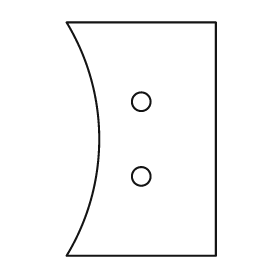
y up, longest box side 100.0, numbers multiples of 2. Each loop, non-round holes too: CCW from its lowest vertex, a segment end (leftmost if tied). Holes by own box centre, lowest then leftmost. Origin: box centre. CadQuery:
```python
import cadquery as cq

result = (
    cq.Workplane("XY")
    .moveTo(-32.0, -50.0)
    .lineTo(32.0, -50.0)
    .lineTo(32.0, 50.0)
    .lineTo(-32.0, 50.0)
    .threePointArc((-18.0, 0.0), (-32.0, -50.0))
    .close()
    .moveTo(0.0, -16.0)
    .circle(4.0)
    .moveTo(0.0, 16.0)
    .circle(4.0)
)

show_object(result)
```